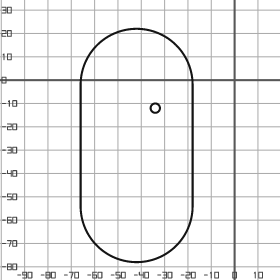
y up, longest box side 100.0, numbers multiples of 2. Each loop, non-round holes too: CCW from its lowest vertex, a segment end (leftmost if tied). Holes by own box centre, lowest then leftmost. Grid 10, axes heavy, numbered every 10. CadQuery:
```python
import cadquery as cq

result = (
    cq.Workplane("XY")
    .moveTo(-66.0, -54.0)
    .threePointArc((-42.0, -78.0), (-18.0, -54.0))
    .lineTo(-18.0, -2.0)
    .threePointArc((-42.0, 22.0), (-66.0, -2.0))
    .close()
    .moveTo(-34.0, -12.0)
    .circle(2.0)
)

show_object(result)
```